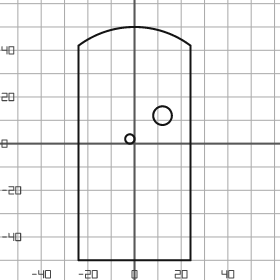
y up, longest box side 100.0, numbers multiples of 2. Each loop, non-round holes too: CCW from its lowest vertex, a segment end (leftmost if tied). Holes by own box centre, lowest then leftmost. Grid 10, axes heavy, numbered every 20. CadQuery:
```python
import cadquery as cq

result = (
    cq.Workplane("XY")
    .moveTo(-24.0, -50.0)
    .lineTo(24.0, -50.0)
    .lineTo(24.0, 42.0)
    .threePointArc((0.0, 50.0), (-24.0, 42.0))
    .close()
    .moveTo(-2.0, 2.0)
    .circle(2.0)
    .moveTo(12.0, 12.0)
    .circle(4.0)
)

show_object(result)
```